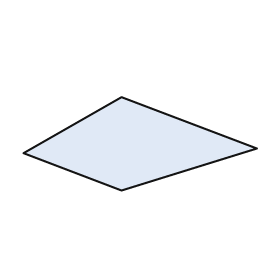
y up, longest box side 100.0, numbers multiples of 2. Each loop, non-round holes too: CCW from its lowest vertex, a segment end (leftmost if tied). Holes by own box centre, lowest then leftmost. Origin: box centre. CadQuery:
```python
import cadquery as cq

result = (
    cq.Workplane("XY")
    .moveTo(-8.0, -20.0)
    .lineTo(50.0, -2.0)
    .lineTo(-8.0, 20.0)
    .lineTo(-50.0, -4.0)
    .close()
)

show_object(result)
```